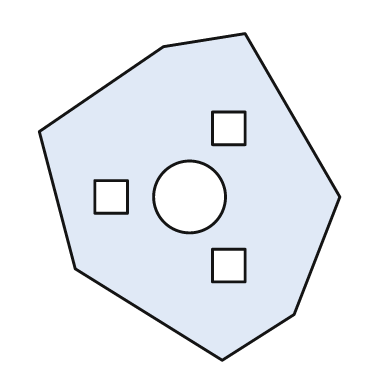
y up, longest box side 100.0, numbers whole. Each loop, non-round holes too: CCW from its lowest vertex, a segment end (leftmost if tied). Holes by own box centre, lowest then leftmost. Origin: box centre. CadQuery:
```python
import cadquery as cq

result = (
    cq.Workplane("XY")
    .moveTo(10.0, -50.0)
    .lineTo(32.0, -36.0)
    .lineTo(46.0, 0.0)
    .lineTo(17.0, 50.0)
    .lineTo(-8.0, 46.0)
    .lineTo(-46.0, 20.0)
    .lineTo(-35.0, -22.0)
    .close()
    .moveTo(7.0, -26.0)
    .lineTo(17.0, -26.0)
    .lineTo(17.0, -16.0)
    .lineTo(7.0, -16.0)
    .close()
    .moveTo(-29.0, -5.0)
    .lineTo(-19.0, -5.0)
    .lineTo(-19.0, 5.0)
    .lineTo(-29.0, 5.0)
    .close()
    .moveTo(0.0, 0.0)
    .circle(11.0)
    .moveTo(7.0, 16.0)
    .lineTo(17.0, 16.0)
    .lineTo(17.0, 26.0)
    .lineTo(7.0, 26.0)
    .close()
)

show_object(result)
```